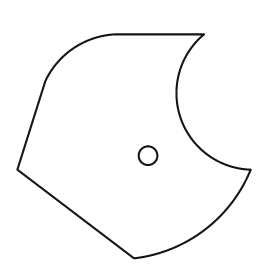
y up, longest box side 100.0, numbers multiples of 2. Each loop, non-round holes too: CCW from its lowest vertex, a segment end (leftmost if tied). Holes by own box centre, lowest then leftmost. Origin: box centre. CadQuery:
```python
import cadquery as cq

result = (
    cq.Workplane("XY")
    .moveTo(0.0, -48.0)
    .threePointArc((30.0, -36.0), (50.0, -10.0))
    .threePointArc((20.0, 12.0), (30.0, 48.0))
    .lineTo(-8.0, 48.0)
    .threePointArc((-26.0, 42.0), (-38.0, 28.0))
    .lineTo(-50.0, -10.0)
    .close()
    .moveTo(6.0, -4.0)
    .circle(4.0)
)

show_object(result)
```